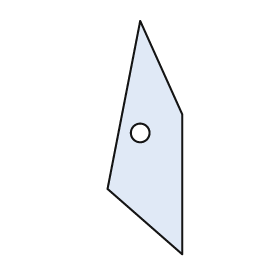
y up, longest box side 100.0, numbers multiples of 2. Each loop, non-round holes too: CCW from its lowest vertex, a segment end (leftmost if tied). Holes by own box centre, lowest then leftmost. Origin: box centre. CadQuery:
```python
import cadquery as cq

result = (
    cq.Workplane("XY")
    .moveTo(16.0, -50.0)
    .lineTo(16.0, 10.0)
    .lineTo(-2.0, 50.0)
    .lineTo(-16.0, -22.0)
    .close()
    .moveTo(-2.0, 2.0)
    .circle(4.0)
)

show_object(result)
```